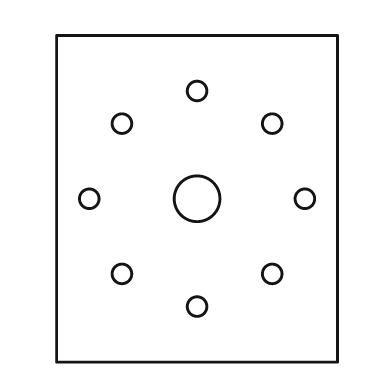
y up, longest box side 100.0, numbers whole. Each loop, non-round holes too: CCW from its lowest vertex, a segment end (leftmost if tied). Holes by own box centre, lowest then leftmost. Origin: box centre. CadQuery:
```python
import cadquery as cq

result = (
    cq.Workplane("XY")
    .moveTo(-43.0, -50.0)
    .lineTo(43.0, -50.0)
    .lineTo(43.0, 50.0)
    .lineTo(-43.0, 50.0)
    .close()
    .moveTo(0.0, -33.0)
    .circle(3.0)
    .moveTo(-23.0, -23.0)
    .circle(3.0)
    .moveTo(23.0, -23.0)
    .circle(3.0)
    .moveTo(-33.0, 0.0)
    .circle(3.0)
    .moveTo(0.0, 0.0)
    .circle(7.0)
    .moveTo(33.0, 0.0)
    .circle(3.0)
    .moveTo(-23.0, 23.0)
    .circle(3.0)
    .moveTo(23.0, 23.0)
    .circle(3.0)
    .moveTo(0.0, 33.0)
    .circle(3.0)
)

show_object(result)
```